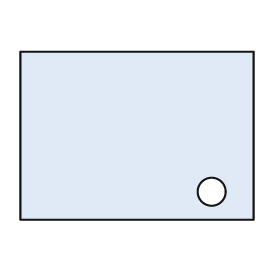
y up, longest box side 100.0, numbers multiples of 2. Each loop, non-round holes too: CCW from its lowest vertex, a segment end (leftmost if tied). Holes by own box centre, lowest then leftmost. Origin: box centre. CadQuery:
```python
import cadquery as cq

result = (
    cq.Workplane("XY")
    .moveTo(-50.0, -36.0)
    .lineTo(50.0, -36.0)
    .lineTo(50.0, 36.0)
    .lineTo(-50.0, 36.0)
    .close()
    .moveTo(32.0, -24.0)
    .circle(6.0)
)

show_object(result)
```